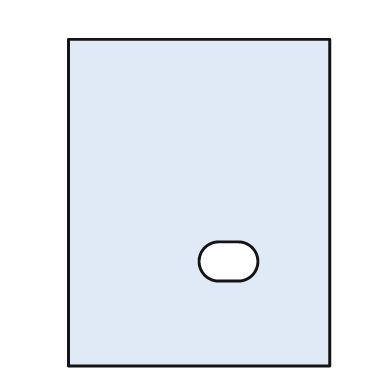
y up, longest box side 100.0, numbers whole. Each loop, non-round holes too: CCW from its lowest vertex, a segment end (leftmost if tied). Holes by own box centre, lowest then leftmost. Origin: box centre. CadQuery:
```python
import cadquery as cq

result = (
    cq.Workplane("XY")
    .moveTo(-40.0, -50.0)
    .lineTo(40.0, -50.0)
    .lineTo(40.0, 50.0)
    .lineTo(-40.0, 50.0)
    .close()
    .moveTo(6.0, -24.0)
    .lineTo(12.0, -24.0)
    .threePointArc((18.0, -18.0), (12.0, -12.0))
    .lineTo(6.0, -12.0)
    .threePointArc((0.0, -18.0), (6.0, -24.0))
    .close()
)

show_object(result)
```